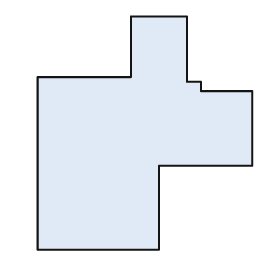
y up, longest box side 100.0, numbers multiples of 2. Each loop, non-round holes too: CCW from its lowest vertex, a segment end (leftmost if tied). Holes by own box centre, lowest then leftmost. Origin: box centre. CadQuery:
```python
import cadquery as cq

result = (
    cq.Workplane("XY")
    .moveTo(-46.0, -50.0)
    .lineTo(6.0, -50.0)
    .lineTo(6.0, -14.0)
    .lineTo(46.0, -14.0)
    .lineTo(46.0, 18.0)
    .lineTo(24.0, 18.0)
    .lineTo(24.0, 22.0)
    .lineTo(18.0, 22.0)
    .lineTo(18.0, 50.0)
    .lineTo(-6.0, 50.0)
    .lineTo(-6.0, 24.0)
    .lineTo(-46.0, 24.0)
    .close()
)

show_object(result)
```